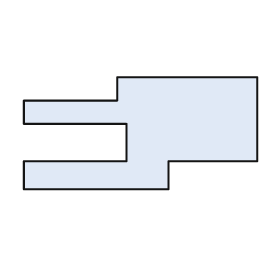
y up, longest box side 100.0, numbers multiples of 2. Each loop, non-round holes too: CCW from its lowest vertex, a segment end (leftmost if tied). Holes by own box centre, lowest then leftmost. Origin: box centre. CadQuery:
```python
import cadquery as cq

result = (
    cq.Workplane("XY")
    .moveTo(-50.0, -24.0)
    .lineTo(12.0, -24.0)
    .lineTo(12.0, -12.0)
    .lineTo(50.0, -12.0)
    .lineTo(50.0, 24.0)
    .lineTo(-10.0, 24.0)
    .lineTo(-10.0, 14.0)
    .lineTo(-50.0, 14.0)
    .lineTo(-50.0, 4.0)
    .lineTo(-6.0, 4.0)
    .lineTo(-6.0, -12.0)
    .lineTo(-50.0, -12.0)
    .close()
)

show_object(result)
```